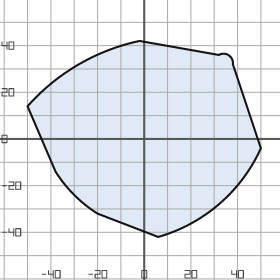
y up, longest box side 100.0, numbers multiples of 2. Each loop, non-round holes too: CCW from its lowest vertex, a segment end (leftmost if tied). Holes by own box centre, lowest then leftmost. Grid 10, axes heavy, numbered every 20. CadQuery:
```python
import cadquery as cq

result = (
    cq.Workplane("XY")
    .moveTo(6.0, -42.0)
    .threePointArc((32.0, -28.0), (50.0, -4.0))
    .lineTo(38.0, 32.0)
    .threePointArc((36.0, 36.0), (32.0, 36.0))
    .lineTo(-2.0, 42.0)
    .threePointArc((-28.0, 32.0), (-50.0, 14.0))
    .lineTo(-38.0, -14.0)
    .threePointArc((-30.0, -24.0), (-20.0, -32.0))
    .close()
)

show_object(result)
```